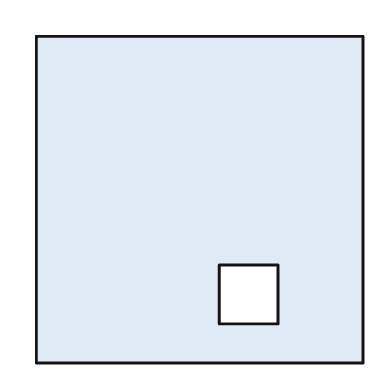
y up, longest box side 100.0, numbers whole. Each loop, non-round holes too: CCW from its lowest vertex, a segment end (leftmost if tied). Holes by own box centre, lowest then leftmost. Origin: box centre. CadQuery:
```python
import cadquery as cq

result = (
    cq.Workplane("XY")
    .moveTo(-50.0, -50.0)
    .lineTo(50.0, -50.0)
    .lineTo(50.0, 50.0)
    .lineTo(-50.0, 50.0)
    .close()
    .moveTo(6.0, -38.0)
    .lineTo(24.0, -38.0)
    .lineTo(24.0, -20.0)
    .lineTo(6.0, -20.0)
    .close()
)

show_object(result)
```